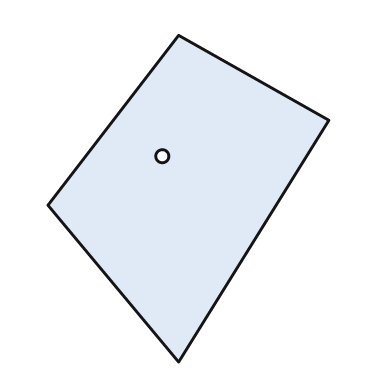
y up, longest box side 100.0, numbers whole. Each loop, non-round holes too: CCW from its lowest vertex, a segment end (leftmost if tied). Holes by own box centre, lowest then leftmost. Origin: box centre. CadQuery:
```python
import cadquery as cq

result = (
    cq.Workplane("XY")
    .moveTo(-3.0, -50.0)
    .lineTo(43.0, 24.0)
    .lineTo(-3.0, 50.0)
    .lineTo(-43.0, -2.0)
    .close()
    .moveTo(-8.0, 13.0)
    .circle(2.0)
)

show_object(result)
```